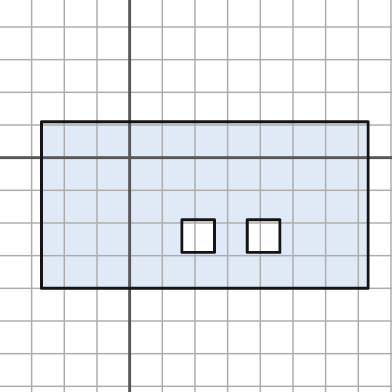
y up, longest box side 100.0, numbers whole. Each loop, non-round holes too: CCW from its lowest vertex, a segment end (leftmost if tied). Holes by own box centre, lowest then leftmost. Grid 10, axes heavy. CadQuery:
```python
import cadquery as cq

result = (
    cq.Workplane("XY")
    .moveTo(-27.0, -40.0)
    .lineTo(73.0, -40.0)
    .lineTo(73.0, 11.0)
    .lineTo(-27.0, 11.0)
    .close()
    .moveTo(16.0, -29.0)
    .lineTo(26.0, -29.0)
    .lineTo(26.0, -19.0)
    .lineTo(16.0, -19.0)
    .close()
    .moveTo(36.0, -29.0)
    .lineTo(46.0, -29.0)
    .lineTo(46.0, -19.0)
    .lineTo(36.0, -19.0)
    .close()
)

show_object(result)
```